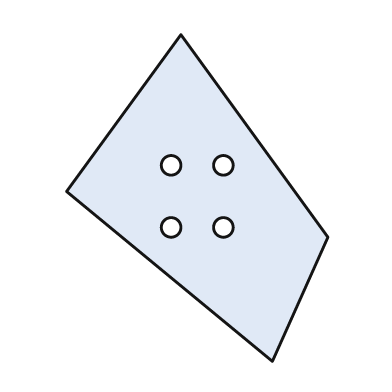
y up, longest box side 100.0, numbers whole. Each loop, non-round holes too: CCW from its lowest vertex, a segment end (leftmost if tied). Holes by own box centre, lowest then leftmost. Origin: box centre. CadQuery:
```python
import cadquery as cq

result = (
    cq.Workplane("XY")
    .moveTo(23.0, -50.0)
    .lineTo(40.0, -12.0)
    .lineTo(-5.0, 50.0)
    .lineTo(-40.0, 2.0)
    .close()
    .moveTo(-8.0, -9.0)
    .circle(3.0)
    .moveTo(8.0, -9.0)
    .circle(3.0)
    .moveTo(-8.0, 10.0)
    .circle(3.0)
    .moveTo(8.0, 10.0)
    .circle(3.0)
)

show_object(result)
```